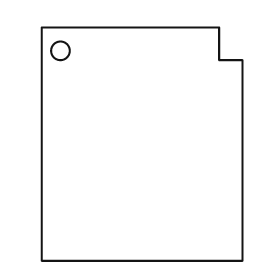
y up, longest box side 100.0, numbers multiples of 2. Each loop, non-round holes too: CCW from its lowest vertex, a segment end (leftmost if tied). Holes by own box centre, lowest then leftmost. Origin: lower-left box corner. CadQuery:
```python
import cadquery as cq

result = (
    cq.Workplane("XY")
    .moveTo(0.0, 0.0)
    .lineTo(86.0, 0.0)
    .lineTo(86.0, 86.0)
    .lineTo(76.0, 86.0)
    .lineTo(76.0, 100.0)
    .lineTo(0.0, 100.0)
    .close()
    .moveTo(8.0, 90.0)
    .circle(4.0)
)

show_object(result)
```